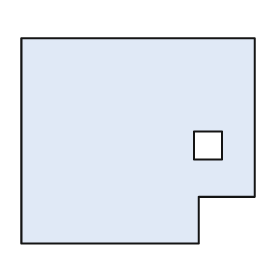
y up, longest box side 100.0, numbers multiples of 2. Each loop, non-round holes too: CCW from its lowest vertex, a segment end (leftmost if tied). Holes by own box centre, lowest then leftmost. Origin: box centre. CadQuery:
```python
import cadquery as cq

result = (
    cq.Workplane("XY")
    .moveTo(-50.0, -44.0)
    .lineTo(26.0, -44.0)
    .lineTo(26.0, -24.0)
    .lineTo(50.0, -24.0)
    .lineTo(50.0, 44.0)
    .lineTo(-50.0, 44.0)
    .close()
    .moveTo(24.0, -8.0)
    .lineTo(36.0, -8.0)
    .lineTo(36.0, 4.0)
    .lineTo(24.0, 4.0)
    .close()
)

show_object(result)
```